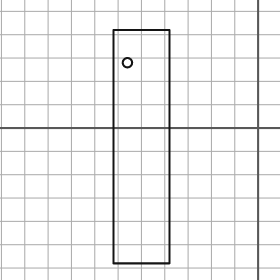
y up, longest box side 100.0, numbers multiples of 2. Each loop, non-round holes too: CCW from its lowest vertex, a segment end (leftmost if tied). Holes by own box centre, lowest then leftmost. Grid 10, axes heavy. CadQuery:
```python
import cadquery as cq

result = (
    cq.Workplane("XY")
    .moveTo(-62.0, -58.0)
    .lineTo(-38.0, -58.0)
    .lineTo(-38.0, 42.0)
    .lineTo(-62.0, 42.0)
    .close()
    .moveTo(-56.0, 28.0)
    .circle(2.0)
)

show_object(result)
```